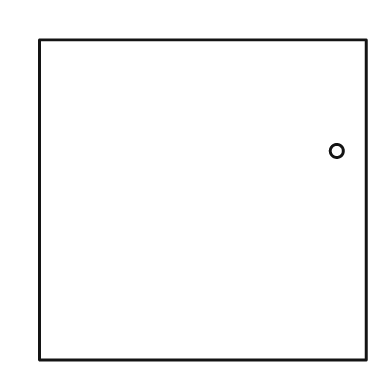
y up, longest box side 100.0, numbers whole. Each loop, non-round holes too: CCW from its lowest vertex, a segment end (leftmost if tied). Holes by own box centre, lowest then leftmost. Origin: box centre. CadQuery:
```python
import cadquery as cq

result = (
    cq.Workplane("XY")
    .moveTo(-50.0, -49.0)
    .lineTo(50.0, -49.0)
    .lineTo(50.0, 49.0)
    .lineTo(-50.0, 49.0)
    .close()
    .moveTo(41.0, 15.0)
    .circle(2.0)
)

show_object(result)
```